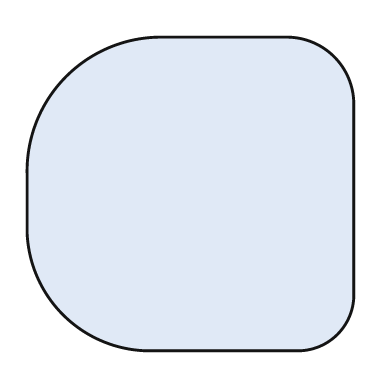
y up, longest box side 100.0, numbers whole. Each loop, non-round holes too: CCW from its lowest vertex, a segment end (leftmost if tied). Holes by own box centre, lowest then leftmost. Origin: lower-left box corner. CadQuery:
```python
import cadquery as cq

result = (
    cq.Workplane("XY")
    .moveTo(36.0, 0.0)
    .lineTo(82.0, 0.0)
    .threePointArc((95.0, 5.0), (100.0, 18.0))
    .lineTo(100.0, 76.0)
    .threePointArc((94.0, 90.0), (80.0, 96.0))
    .lineTo(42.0, 96.0)
    .threePointArc((12.0, 84.0), (0.0, 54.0))
    .lineTo(0.0, 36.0)
    .threePointArc((11.0, 11.0), (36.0, 0.0))
    .close()
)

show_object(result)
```